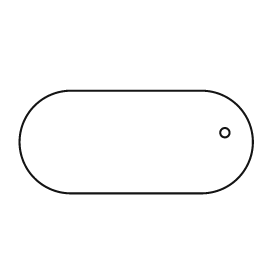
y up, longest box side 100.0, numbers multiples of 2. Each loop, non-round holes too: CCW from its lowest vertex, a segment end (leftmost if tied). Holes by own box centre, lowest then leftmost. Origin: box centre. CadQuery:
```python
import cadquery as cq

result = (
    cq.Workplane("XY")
    .moveTo(-28.0, -22.0)
    .lineTo(28.0, -22.0)
    .threePointArc((50.0, 0.0), (28.0, 22.0))
    .lineTo(-28.0, 22.0)
    .threePointArc((-50.0, 0.0), (-28.0, -22.0))
    .close()
    .moveTo(38.0, 4.0)
    .circle(2.0)
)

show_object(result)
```